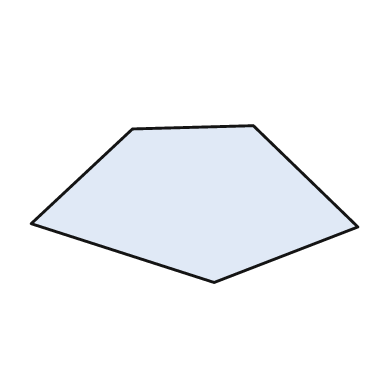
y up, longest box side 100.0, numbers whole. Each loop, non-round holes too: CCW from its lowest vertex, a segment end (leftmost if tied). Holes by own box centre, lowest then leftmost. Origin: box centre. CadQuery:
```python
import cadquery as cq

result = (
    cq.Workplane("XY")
    .moveTo(6.0, -24.0)
    .lineTo(50.0, -7.0)
    .lineTo(18.0, 24.0)
    .lineTo(-19.0, 23.0)
    .lineTo(-50.0, -6.0)
    .close()
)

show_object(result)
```